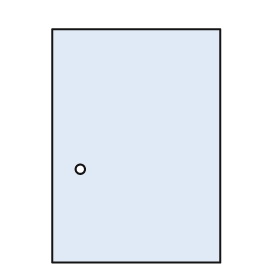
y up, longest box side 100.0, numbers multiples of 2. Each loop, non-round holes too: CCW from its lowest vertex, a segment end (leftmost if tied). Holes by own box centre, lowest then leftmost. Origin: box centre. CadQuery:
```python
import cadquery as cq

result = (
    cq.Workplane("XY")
    .moveTo(-36.0, -50.0)
    .lineTo(36.0, -50.0)
    .lineTo(36.0, 50.0)
    .lineTo(-36.0, 50.0)
    .close()
    .moveTo(-24.0, -10.0)
    .circle(2.0)
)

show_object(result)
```